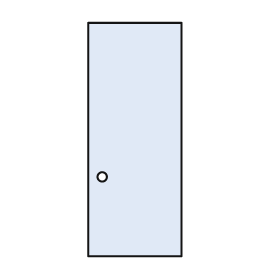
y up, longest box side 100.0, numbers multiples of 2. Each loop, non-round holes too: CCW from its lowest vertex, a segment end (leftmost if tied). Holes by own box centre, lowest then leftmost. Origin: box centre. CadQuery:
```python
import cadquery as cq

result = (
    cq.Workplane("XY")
    .moveTo(-20.0, -50.0)
    .lineTo(20.0, -50.0)
    .lineTo(20.0, 50.0)
    .lineTo(-20.0, 50.0)
    .close()
    .moveTo(-14.0, -16.0)
    .circle(2.0)
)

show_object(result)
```